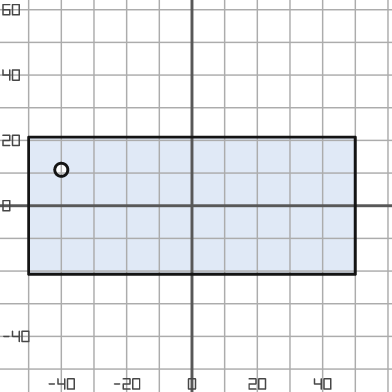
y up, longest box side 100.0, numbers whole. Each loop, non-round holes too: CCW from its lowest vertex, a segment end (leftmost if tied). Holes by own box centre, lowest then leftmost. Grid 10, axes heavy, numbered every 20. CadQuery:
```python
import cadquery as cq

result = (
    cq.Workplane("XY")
    .moveTo(-50.0, -21.0)
    .lineTo(50.0, -21.0)
    .lineTo(50.0, 21.0)
    .lineTo(-50.0, 21.0)
    .close()
    .moveTo(-40.0, 11.0)
    .circle(2.0)
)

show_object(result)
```